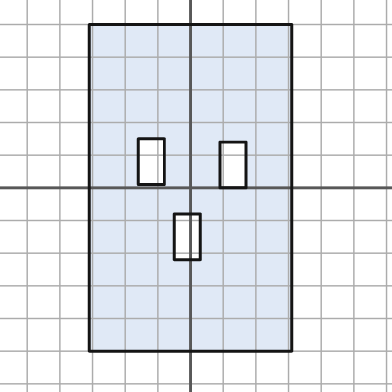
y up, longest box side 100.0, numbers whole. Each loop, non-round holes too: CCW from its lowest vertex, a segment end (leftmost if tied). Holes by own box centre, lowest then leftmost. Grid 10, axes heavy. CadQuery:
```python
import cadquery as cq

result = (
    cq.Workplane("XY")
    .moveTo(-31.0, -50.0)
    .lineTo(31.0, -50.0)
    .lineTo(31.0, 50.0)
    .lineTo(-31.0, 50.0)
    .close()
    .moveTo(-5.0, -22.0)
    .lineTo(3.0, -22.0)
    .lineTo(3.0, -8.0)
    .lineTo(-5.0, -8.0)
    .close()
    .moveTo(9.0, 0.0)
    .lineTo(17.0, 0.0)
    .lineTo(17.0, 14.0)
    .lineTo(9.0, 14.0)
    .close()
    .moveTo(-16.0, 1.0)
    .lineTo(-8.0, 1.0)
    .lineTo(-8.0, 15.0)
    .lineTo(-16.0, 15.0)
    .close()
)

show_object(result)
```